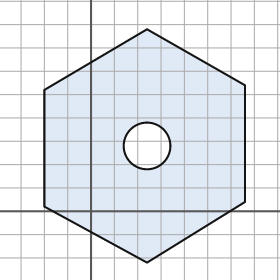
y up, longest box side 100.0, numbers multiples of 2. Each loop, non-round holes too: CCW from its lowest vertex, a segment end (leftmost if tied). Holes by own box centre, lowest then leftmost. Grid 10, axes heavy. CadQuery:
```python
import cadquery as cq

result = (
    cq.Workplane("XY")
    .moveTo(24.0, -22.0)
    .lineTo(66.0, 4.0)
    .lineTo(66.0, 54.0)
    .lineTo(24.0, 78.0)
    .lineTo(-20.0, 52.0)
    .lineTo(-20.0, 2.0)
    .close()
    .moveTo(24.0, 28.0)
    .circle(10.0)
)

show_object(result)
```